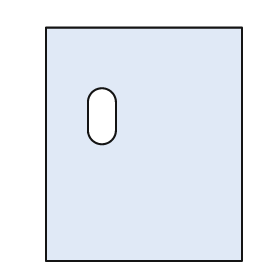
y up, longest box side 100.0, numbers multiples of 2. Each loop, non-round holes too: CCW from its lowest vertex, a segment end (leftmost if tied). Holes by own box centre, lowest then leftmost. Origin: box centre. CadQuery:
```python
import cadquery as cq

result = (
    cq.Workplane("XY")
    .moveTo(-42.0, -50.0)
    .lineTo(42.0, -50.0)
    .lineTo(42.0, 50.0)
    .lineTo(-42.0, 50.0)
    .close()
    .moveTo(-24.0, 6.0)
    .threePointArc((-18.0, 0.0), (-12.0, 6.0))
    .lineTo(-12.0, 18.0)
    .threePointArc((-18.0, 24.0), (-24.0, 18.0))
    .close()
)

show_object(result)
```